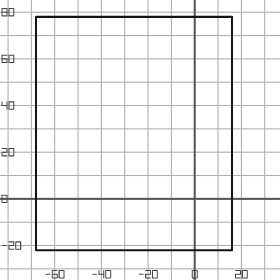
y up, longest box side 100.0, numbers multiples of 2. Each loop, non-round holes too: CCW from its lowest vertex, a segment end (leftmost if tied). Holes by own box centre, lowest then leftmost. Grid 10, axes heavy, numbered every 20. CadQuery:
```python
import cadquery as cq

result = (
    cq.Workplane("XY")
    .moveTo(-68.0, -22.0)
    .lineTo(16.0, -22.0)
    .lineTo(16.0, 78.0)
    .lineTo(-68.0, 78.0)
    .close()
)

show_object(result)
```